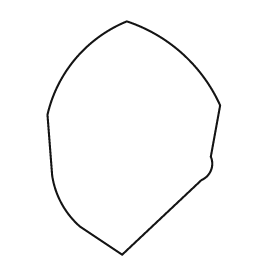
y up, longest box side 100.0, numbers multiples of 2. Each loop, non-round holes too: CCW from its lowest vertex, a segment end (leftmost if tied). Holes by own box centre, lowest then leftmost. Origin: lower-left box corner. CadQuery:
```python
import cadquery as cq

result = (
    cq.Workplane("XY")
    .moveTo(32.0, 0.0)
    .lineTo(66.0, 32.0)
    .threePointArc((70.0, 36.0), (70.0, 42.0))
    .lineTo(74.0, 64.0)
    .threePointArc((58.0, 86.0), (34.0, 100.0))
    .threePointArc((12.0, 84.0), (0.0, 60.0))
    .lineTo(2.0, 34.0)
    .threePointArc((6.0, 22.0), (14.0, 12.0))
    .close()
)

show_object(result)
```